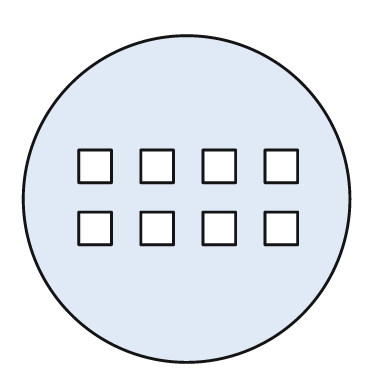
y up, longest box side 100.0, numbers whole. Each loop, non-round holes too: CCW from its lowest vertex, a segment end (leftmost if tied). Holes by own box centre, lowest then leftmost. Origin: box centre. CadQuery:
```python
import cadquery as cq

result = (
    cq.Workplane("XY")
    .moveTo(0.0, 0.0)
    .circle(50.0)
    .moveTo(-33.0, -14.0)
    .lineTo(-23.0, -14.0)
    .lineTo(-23.0, -4.0)
    .lineTo(-33.0, -4.0)
    .close()
    .moveTo(-14.0, -14.0)
    .lineTo(-4.0, -14.0)
    .lineTo(-4.0, -4.0)
    .lineTo(-14.0, -4.0)
    .close()
    .moveTo(5.0, -14.0)
    .lineTo(15.0, -14.0)
    .lineTo(15.0, -4.0)
    .lineTo(5.0, -4.0)
    .close()
    .moveTo(24.0, -14.0)
    .lineTo(34.0, -14.0)
    .lineTo(34.0, -4.0)
    .lineTo(24.0, -4.0)
    .close()
    .moveTo(-33.0, 5.0)
    .lineTo(-23.0, 5.0)
    .lineTo(-23.0, 15.0)
    .lineTo(-33.0, 15.0)
    .close()
    .moveTo(-14.0, 5.0)
    .lineTo(-4.0, 5.0)
    .lineTo(-4.0, 15.0)
    .lineTo(-14.0, 15.0)
    .close()
    .moveTo(5.0, 5.0)
    .lineTo(15.0, 5.0)
    .lineTo(15.0, 15.0)
    .lineTo(5.0, 15.0)
    .close()
    .moveTo(24.0, 5.0)
    .lineTo(34.0, 5.0)
    .lineTo(34.0, 15.0)
    .lineTo(24.0, 15.0)
    .close()
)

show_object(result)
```